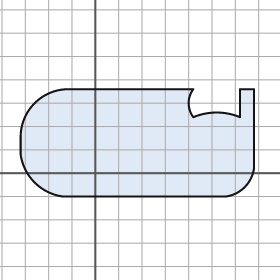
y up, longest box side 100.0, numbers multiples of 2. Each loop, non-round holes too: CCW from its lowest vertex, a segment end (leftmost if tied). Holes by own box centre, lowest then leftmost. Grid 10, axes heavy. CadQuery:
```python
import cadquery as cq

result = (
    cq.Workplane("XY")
    .moveTo(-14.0, -10.0)
    .lineTo(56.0, -10.0)
    .threePointArc((64.0, -6.0), (68.0, 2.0))
    .lineTo(68.0, 36.0)
    .lineTo(62.0, 36.0)
    .lineTo(62.0, 24.0)
    .threePointArc((52.0, 26.0), (42.0, 24.0))
    .threePointArc((40.0, 30.0), (42.0, 36.0))
    .lineTo(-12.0, 36.0)
    .threePointArc((-26.0, 30.0), (-32.0, 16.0))
    .lineTo(-32.0, 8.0)
    .threePointArc((-26.0, -4.0), (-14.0, -10.0))
    .close()
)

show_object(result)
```